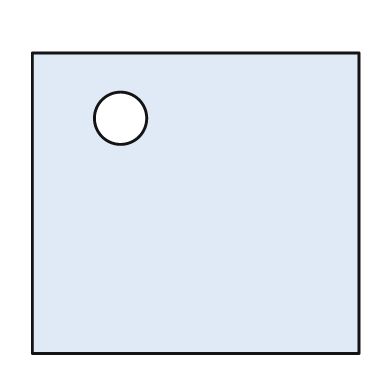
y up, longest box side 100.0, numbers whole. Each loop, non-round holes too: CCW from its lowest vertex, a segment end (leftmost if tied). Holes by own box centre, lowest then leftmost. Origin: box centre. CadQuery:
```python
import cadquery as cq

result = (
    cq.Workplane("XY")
    .moveTo(-50.0, -46.0)
    .lineTo(50.0, -46.0)
    .lineTo(50.0, 46.0)
    .lineTo(-50.0, 46.0)
    .close()
    .moveTo(-23.0, 26.0)
    .circle(8.0)
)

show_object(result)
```